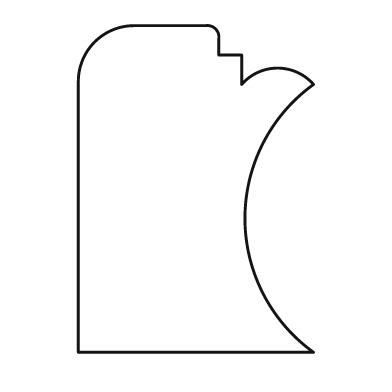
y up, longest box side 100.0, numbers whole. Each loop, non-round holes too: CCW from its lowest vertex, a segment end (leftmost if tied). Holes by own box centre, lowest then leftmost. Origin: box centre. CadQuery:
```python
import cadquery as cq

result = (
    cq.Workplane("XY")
    .moveTo(-36.0, -50.0)
    .lineTo(36.0, -50.0)
    .threePointArc((15.0, -9.0), (36.0, 32.0))
    .threePointArc((25.0, 37.0), (14.0, 32.0))
    .lineTo(14.0, 41.0)
    .lineTo(7.0, 41.0)
    .lineTo(7.0, 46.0)
    .threePointArc((6.0, 49.0), (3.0, 50.0))
    .lineTo(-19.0, 50.0)
    .threePointArc((-31.0, 45.0), (-36.0, 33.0))
    .close()
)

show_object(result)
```